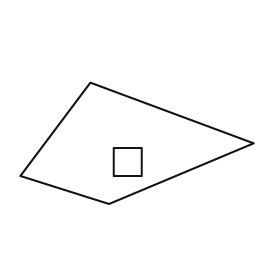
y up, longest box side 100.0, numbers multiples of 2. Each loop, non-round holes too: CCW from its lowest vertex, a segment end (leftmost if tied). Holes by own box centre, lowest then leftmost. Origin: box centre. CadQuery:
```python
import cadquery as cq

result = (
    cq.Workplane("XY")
    .moveTo(-12.0, -26.0)
    .lineTo(50.0, 0.0)
    .lineTo(-20.0, 26.0)
    .lineTo(-50.0, -14.0)
    .close()
    .moveTo(-10.0, -14.0)
    .lineTo(2.0, -14.0)
    .lineTo(2.0, -2.0)
    .lineTo(-10.0, -2.0)
    .close()
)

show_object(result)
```